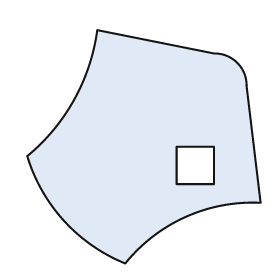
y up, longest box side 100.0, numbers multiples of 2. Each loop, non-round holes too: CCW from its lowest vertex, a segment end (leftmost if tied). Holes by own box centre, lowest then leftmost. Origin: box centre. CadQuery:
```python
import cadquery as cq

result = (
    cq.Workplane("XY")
    .moveTo(-8.0, -50.0)
    .threePointArc((18.0, -30.0), (50.0, -24.0))
    .lineTo(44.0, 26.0)
    .threePointArc((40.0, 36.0), (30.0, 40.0))
    .lineTo(-20.0, 50.0)
    .threePointArc((-30.0, 20.0), (-50.0, -4.0))
    .threePointArc((-34.0, -32.0), (-8.0, -50.0))
    .close()
    .moveTo(14.0, -16.0)
    .lineTo(30.0, -16.0)
    .lineTo(30.0, 0.0)
    .lineTo(14.0, 0.0)
    .close()
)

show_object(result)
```